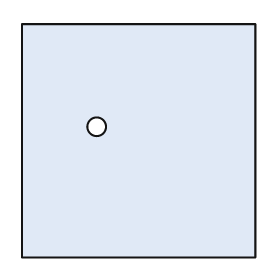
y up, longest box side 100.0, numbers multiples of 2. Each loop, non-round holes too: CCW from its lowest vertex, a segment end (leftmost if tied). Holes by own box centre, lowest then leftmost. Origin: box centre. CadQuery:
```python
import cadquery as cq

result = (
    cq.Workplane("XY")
    .moveTo(-50.0, -50.0)
    .lineTo(50.0, -50.0)
    .lineTo(50.0, 50.0)
    .lineTo(-50.0, 50.0)
    .close()
    .moveTo(-18.0, 6.0)
    .circle(4.0)
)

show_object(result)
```